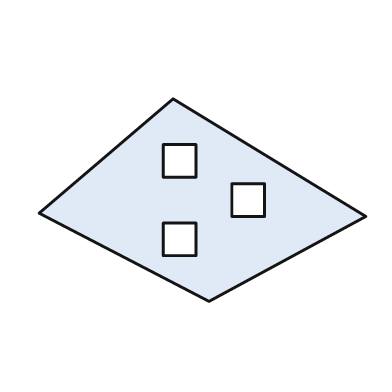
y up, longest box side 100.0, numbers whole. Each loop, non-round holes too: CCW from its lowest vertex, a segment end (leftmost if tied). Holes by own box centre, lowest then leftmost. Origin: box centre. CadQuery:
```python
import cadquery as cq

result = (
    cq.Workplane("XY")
    .moveTo(2.0, -31.0)
    .lineTo(50.0, -5.0)
    .lineTo(-9.0, 31.0)
    .lineTo(-50.0, -4.0)
    .close()
    .moveTo(-12.0, -17.0)
    .lineTo(-2.0, -17.0)
    .lineTo(-2.0, -7.0)
    .lineTo(-12.0, -7.0)
    .close()
    .moveTo(9.0, -5.0)
    .lineTo(19.0, -5.0)
    .lineTo(19.0, 5.0)
    .lineTo(9.0, 5.0)
    .close()
    .moveTo(-12.0, 7.0)
    .lineTo(-2.0, 7.0)
    .lineTo(-2.0, 17.0)
    .lineTo(-12.0, 17.0)
    .close()
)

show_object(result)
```